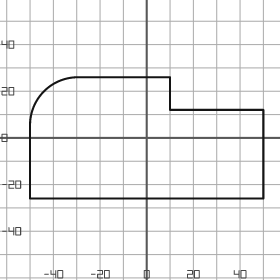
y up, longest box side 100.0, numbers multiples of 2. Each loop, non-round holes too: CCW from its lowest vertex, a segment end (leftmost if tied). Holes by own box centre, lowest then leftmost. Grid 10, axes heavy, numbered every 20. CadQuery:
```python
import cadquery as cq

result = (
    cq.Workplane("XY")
    .moveTo(-50.0, -26.0)
    .lineTo(50.0, -26.0)
    .lineTo(50.0, 12.0)
    .lineTo(10.0, 12.0)
    .lineTo(10.0, 26.0)
    .lineTo(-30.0, 26.0)
    .threePointArc((-44.0, 20.0), (-50.0, 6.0))
    .close()
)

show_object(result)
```